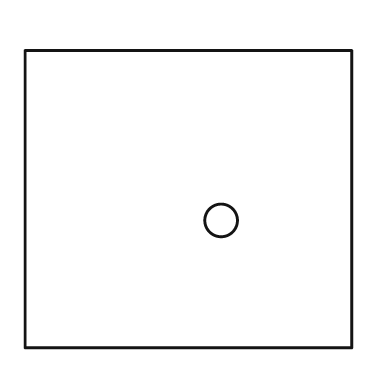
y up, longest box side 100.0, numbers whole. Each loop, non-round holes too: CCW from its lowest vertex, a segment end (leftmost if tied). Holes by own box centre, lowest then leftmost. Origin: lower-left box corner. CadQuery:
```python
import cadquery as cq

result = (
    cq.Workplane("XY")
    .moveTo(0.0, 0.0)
    .lineTo(100.0, 0.0)
    .lineTo(100.0, 91.0)
    .lineTo(0.0, 91.0)
    .close()
    .moveTo(60.0, 39.0)
    .circle(5.0)
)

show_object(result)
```